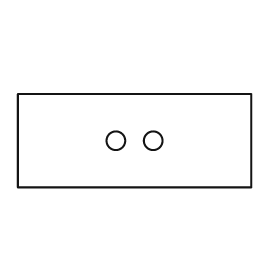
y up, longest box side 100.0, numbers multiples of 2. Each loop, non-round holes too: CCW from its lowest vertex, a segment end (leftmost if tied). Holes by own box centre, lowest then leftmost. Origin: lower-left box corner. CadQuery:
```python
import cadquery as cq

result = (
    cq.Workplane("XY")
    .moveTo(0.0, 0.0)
    .lineTo(100.0, 0.0)
    .lineTo(100.0, 40.0)
    .lineTo(0.0, 40.0)
    .close()
    .moveTo(42.0, 20.0)
    .circle(4.0)
    .moveTo(58.0, 20.0)
    .circle(4.0)
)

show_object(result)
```